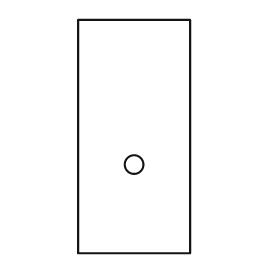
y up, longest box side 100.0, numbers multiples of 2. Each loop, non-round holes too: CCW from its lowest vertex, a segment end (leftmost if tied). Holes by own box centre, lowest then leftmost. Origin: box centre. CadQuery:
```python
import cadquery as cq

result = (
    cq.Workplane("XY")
    .moveTo(-24.0, -50.0)
    .lineTo(24.0, -50.0)
    .lineTo(24.0, 50.0)
    .lineTo(-24.0, 50.0)
    .close()
    .moveTo(0.0, -12.0)
    .circle(4.0)
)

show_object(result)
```